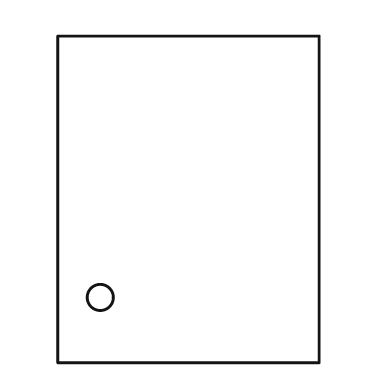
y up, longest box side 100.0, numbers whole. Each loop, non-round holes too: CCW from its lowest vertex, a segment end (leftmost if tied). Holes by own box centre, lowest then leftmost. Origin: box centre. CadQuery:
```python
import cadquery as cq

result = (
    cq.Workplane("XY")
    .moveTo(-40.0, -50.0)
    .lineTo(40.0, -50.0)
    .lineTo(40.0, 50.0)
    .lineTo(-40.0, 50.0)
    .close()
    .moveTo(-27.0, -30.0)
    .circle(4.0)
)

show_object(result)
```